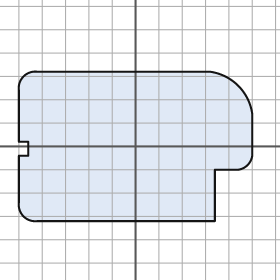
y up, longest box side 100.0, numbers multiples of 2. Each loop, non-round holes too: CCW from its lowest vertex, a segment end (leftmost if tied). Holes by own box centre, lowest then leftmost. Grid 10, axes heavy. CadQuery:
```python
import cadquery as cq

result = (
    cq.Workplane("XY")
    .moveTo(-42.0, -32.0)
    .lineTo(34.0, -32.0)
    .lineTo(34.0, -10.0)
    .lineTo(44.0, -10.0)
    .threePointArc((48.0, -8.0), (50.0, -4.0))
    .lineTo(50.0, 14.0)
    .threePointArc((44.0, 26.0), (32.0, 32.0))
    .lineTo(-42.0, 32.0)
    .threePointArc((-48.0, 30.0), (-50.0, 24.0))
    .lineTo(-50.0, 2.0)
    .lineTo(-46.0, 2.0)
    .lineTo(-46.0, -4.0)
    .lineTo(-50.0, -4.0)
    .lineTo(-50.0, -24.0)
    .threePointArc((-48.0, -30.0), (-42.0, -32.0))
    .close()
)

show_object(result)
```